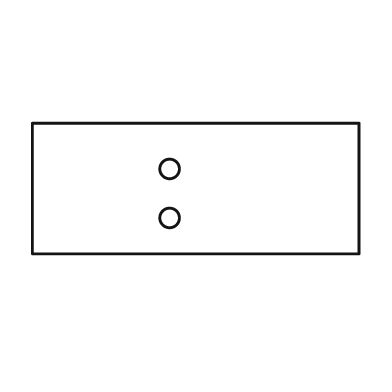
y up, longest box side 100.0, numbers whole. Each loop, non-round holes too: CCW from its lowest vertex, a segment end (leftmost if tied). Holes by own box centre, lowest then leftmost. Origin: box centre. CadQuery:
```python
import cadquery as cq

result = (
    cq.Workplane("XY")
    .moveTo(-50.0, -20.0)
    .lineTo(50.0, -20.0)
    .lineTo(50.0, 20.0)
    .lineTo(-50.0, 20.0)
    .close()
    .moveTo(-8.0, -9.0)
    .circle(3.0)
    .moveTo(-8.0, 6.0)
    .circle(3.0)
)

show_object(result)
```